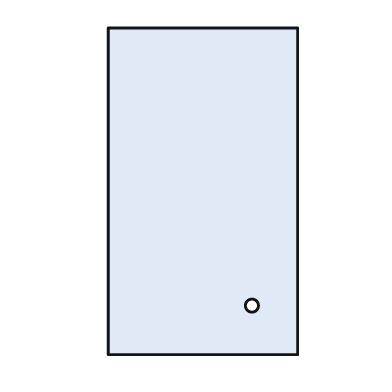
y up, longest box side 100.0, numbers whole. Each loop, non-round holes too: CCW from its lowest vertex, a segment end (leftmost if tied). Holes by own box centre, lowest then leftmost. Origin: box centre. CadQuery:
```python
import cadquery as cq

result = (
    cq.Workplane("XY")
    .moveTo(-29.0, -50.0)
    .lineTo(29.0, -50.0)
    .lineTo(29.0, 50.0)
    .lineTo(-29.0, 50.0)
    .close()
    .moveTo(15.0, -35.0)
    .circle(2.0)
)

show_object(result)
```